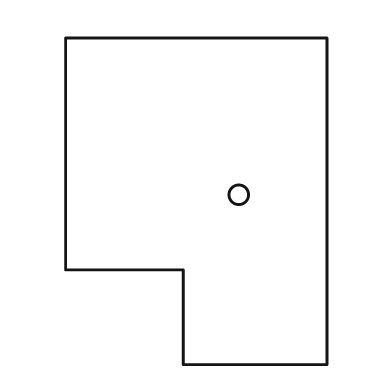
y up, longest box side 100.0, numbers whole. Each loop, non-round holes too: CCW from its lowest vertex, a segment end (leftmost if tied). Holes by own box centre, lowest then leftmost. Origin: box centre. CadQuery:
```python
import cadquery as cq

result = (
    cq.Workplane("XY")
    .moveTo(-4.0, -50.0)
    .lineTo(40.0, -50.0)
    .lineTo(40.0, 50.0)
    .lineTo(-40.0, 50.0)
    .lineTo(-40.0, -21.0)
    .lineTo(-4.0, -21.0)
    .close()
    .moveTo(13.0, 2.0)
    .circle(3.0)
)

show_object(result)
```